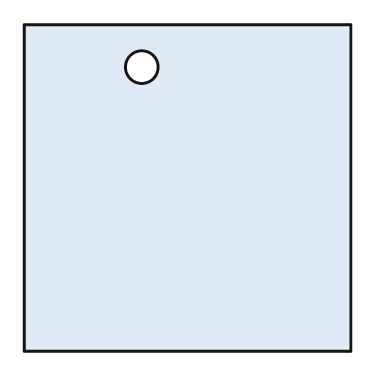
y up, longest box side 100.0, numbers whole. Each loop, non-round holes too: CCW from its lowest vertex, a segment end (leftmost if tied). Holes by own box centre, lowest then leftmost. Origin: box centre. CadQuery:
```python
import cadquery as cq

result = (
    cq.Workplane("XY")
    .moveTo(-50.0, -50.0)
    .lineTo(50.0, -50.0)
    .lineTo(50.0, 50.0)
    .lineTo(-50.0, 50.0)
    .close()
    .moveTo(-14.0, 37.0)
    .circle(5.0)
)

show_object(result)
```